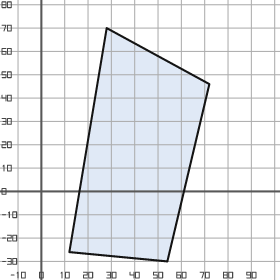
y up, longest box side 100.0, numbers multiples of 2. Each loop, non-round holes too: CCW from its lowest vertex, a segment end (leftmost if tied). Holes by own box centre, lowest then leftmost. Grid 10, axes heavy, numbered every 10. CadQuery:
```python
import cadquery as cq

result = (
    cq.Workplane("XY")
    .moveTo(54.0, -30.0)
    .lineTo(72.0, 46.0)
    .lineTo(28.0, 70.0)
    .lineTo(12.0, -26.0)
    .close()
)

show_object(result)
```